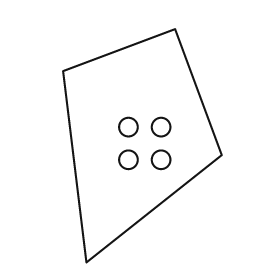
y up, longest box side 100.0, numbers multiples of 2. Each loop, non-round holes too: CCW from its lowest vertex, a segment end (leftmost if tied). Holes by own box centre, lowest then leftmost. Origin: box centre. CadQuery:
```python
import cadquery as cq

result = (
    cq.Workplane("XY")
    .moveTo(-24.0, -50.0)
    .lineTo(34.0, -4.0)
    .lineTo(14.0, 50.0)
    .lineTo(-34.0, 32.0)
    .close()
    .moveTo(-6.0, -6.0)
    .circle(4.0)
    .moveTo(8.0, -6.0)
    .circle(4.0)
    .moveTo(-6.0, 8.0)
    .circle(4.0)
    .moveTo(8.0, 8.0)
    .circle(4.0)
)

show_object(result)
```